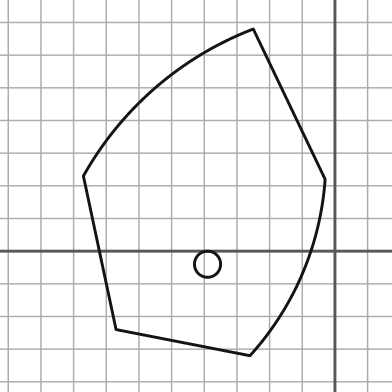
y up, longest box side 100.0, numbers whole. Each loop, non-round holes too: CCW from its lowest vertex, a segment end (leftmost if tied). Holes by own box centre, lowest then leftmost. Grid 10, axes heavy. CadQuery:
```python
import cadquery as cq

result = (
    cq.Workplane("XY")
    .moveTo(-26.0, -32.0)
    .threePointArc((-10.0, -7.0), (-3.0, 22.0))
    .lineTo(-25.0, 68.0)
    .threePointArc((-55.0, 50.0), (-77.0, 23.0))
    .lineTo(-67.0, -24.0)
    .close()
    .moveTo(-39.0, -4.0)
    .circle(4.0)
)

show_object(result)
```